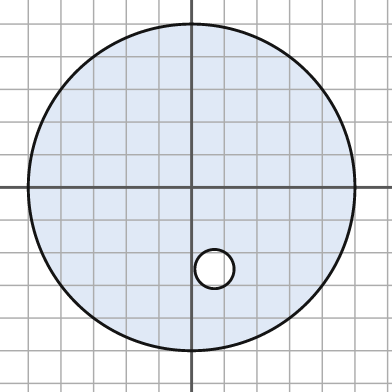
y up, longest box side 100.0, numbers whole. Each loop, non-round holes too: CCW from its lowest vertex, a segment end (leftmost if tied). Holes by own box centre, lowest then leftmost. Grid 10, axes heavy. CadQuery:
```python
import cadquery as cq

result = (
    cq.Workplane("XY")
    .moveTo(0.0, 0.0)
    .circle(50.0)
    .moveTo(7.0, -25.0)
    .circle(6.0)
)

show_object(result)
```